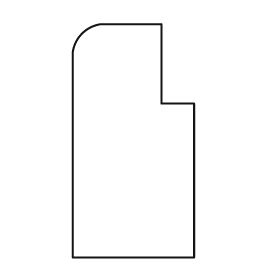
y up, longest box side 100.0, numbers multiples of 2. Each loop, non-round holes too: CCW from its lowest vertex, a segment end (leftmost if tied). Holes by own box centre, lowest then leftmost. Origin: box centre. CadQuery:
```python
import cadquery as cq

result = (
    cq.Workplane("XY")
    .moveTo(-26.0, -50.0)
    .lineTo(26.0, -50.0)
    .lineTo(26.0, 16.0)
    .lineTo(12.0, 16.0)
    .lineTo(12.0, 50.0)
    .lineTo(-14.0, 50.0)
    .threePointArc((-22.0, 46.0), (-26.0, 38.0))
    .close()
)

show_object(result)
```